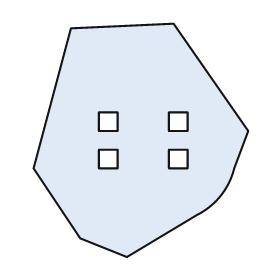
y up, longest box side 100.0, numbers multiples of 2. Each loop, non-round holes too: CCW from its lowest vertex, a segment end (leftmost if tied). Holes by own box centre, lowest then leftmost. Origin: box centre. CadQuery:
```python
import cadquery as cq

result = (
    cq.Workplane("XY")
    .moveTo(-6.0, -50.0)
    .lineTo(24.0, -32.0)
    .threePointArc((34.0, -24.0), (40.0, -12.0))
    .lineTo(46.0, 4.0)
    .lineTo(14.0, 50.0)
    .lineTo(-30.0, 48.0)
    .lineTo(-46.0, -12.0)
    .lineTo(-26.0, -42.0)
    .close()
    .moveTo(-18.0, -12.0)
    .lineTo(-10.0, -12.0)
    .lineTo(-10.0, -4.0)
    .lineTo(-18.0, -4.0)
    .close()
    .moveTo(12.0, -12.0)
    .lineTo(20.0, -12.0)
    .lineTo(20.0, -4.0)
    .lineTo(12.0, -4.0)
    .close()
    .moveTo(-18.0, 4.0)
    .lineTo(-10.0, 4.0)
    .lineTo(-10.0, 12.0)
    .lineTo(-18.0, 12.0)
    .close()
    .moveTo(12.0, 4.0)
    .lineTo(20.0, 4.0)
    .lineTo(20.0, 12.0)
    .lineTo(12.0, 12.0)
    .close()
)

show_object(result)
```